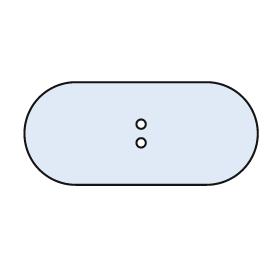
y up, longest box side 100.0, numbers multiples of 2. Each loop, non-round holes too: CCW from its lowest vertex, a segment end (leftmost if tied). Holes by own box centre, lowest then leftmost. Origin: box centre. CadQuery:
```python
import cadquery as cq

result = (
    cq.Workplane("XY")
    .moveTo(-28.0, -22.0)
    .lineTo(28.0, -22.0)
    .threePointArc((50.0, 0.0), (28.0, 22.0))
    .lineTo(-28.0, 22.0)
    .threePointArc((-50.0, 0.0), (-28.0, -22.0))
    .close()
    .moveTo(0.0, -4.0)
    .circle(2.0)
    .moveTo(0.0, 4.0)
    .circle(2.0)
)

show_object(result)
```